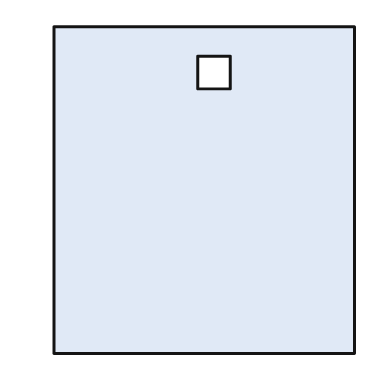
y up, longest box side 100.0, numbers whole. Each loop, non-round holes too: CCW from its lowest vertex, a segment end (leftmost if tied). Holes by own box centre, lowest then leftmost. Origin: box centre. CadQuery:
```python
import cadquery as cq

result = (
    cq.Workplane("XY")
    .moveTo(-46.0, -50.0)
    .lineTo(46.0, -50.0)
    .lineTo(46.0, 50.0)
    .lineTo(-46.0, 50.0)
    .close()
    .moveTo(-2.0, 31.0)
    .lineTo(8.0, 31.0)
    .lineTo(8.0, 41.0)
    .lineTo(-2.0, 41.0)
    .close()
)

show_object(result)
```